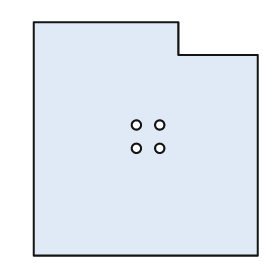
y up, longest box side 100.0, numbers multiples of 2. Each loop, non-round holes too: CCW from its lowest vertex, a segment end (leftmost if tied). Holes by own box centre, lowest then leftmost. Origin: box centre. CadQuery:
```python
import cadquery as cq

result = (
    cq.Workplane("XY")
    .moveTo(-48.0, -50.0)
    .lineTo(48.0, -50.0)
    .lineTo(48.0, 36.0)
    .lineTo(14.0, 36.0)
    .lineTo(14.0, 50.0)
    .lineTo(-48.0, 50.0)
    .close()
    .moveTo(-4.0, -4.0)
    .circle(2.0)
    .moveTo(6.0, -4.0)
    .circle(2.0)
    .moveTo(-4.0, 6.0)
    .circle(2.0)
    .moveTo(6.0, 6.0)
    .circle(2.0)
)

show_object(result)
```